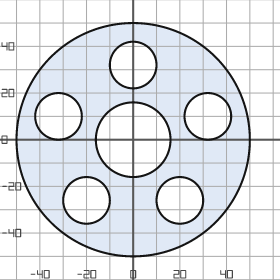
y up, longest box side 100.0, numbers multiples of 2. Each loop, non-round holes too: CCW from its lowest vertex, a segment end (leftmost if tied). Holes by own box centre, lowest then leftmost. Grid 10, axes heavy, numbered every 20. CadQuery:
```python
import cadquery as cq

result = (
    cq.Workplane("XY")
    .moveTo(0.0, 0.0)
    .circle(50.0)
    .moveTo(-20.0, -26.0)
    .circle(10.0)
    .moveTo(20.0, -26.0)
    .circle(10.0)
    .moveTo(0.0, 0.0)
    .circle(16.0)
    .moveTo(-32.0, 10.0)
    .circle(10.0)
    .moveTo(32.0, 10.0)
    .circle(10.0)
    .moveTo(0.0, 32.0)
    .circle(10.0)
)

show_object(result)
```